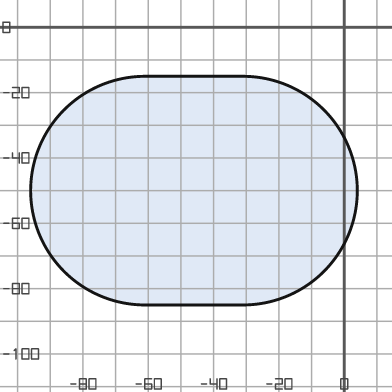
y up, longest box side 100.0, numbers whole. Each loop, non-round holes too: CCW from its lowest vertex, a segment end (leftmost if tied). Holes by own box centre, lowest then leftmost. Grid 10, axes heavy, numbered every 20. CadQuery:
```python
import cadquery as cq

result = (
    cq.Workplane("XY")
    .moveTo(-61.0, -85.0)
    .lineTo(-31.0, -85.0)
    .threePointArc((4.0, -50.0), (-31.0, -15.0))
    .lineTo(-61.0, -15.0)
    .threePointArc((-96.0, -50.0), (-61.0, -85.0))
    .close()
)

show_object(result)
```